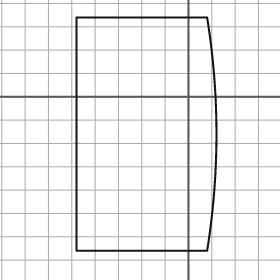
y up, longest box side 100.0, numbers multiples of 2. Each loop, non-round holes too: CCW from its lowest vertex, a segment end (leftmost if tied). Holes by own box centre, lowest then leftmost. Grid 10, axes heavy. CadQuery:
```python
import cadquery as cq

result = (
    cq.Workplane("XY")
    .moveTo(-48.0, -66.0)
    .lineTo(8.0, -66.0)
    .threePointArc((12.0, -16.0), (8.0, 34.0))
    .lineTo(-48.0, 34.0)
    .close()
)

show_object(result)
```